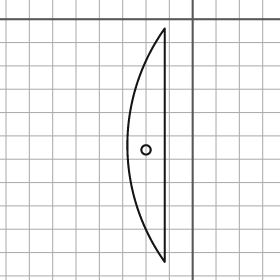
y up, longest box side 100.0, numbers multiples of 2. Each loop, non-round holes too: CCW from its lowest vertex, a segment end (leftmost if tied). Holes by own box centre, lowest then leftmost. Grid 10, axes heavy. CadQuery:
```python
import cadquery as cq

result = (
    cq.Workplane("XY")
    .moveTo(-12.0, -104.0)
    .lineTo(-12.0, -4.0)
    .threePointArc((-28.0, -54.0), (-12.0, -104.0))
    .close()
    .moveTo(-20.0, -56.0)
    .circle(2.0)
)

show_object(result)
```